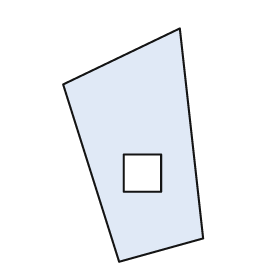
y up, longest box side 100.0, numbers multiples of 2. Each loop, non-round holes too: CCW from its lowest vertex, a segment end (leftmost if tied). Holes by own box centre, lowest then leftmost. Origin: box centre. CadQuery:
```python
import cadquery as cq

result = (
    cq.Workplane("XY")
    .moveTo(-6.0, -50.0)
    .lineTo(30.0, -40.0)
    .lineTo(20.0, 50.0)
    .lineTo(-30.0, 26.0)
    .close()
    .moveTo(-4.0, -20.0)
    .lineTo(12.0, -20.0)
    .lineTo(12.0, -4.0)
    .lineTo(-4.0, -4.0)
    .close()
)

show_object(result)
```